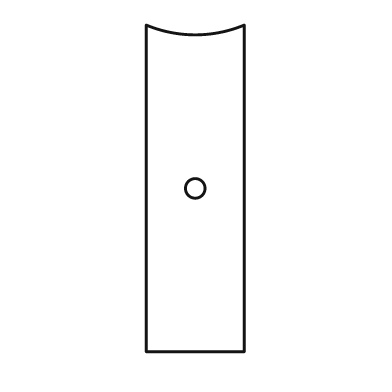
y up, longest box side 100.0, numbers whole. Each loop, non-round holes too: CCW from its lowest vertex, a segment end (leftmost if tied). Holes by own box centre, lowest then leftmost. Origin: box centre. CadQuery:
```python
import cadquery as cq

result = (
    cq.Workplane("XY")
    .moveTo(-15.0, -50.0)
    .lineTo(15.0, -50.0)
    .lineTo(15.0, 50.0)
    .threePointArc((0.0, 47.0), (-15.0, 50.0))
    .close()
    .moveTo(0.0, 0.0)
    .circle(3.0)
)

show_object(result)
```